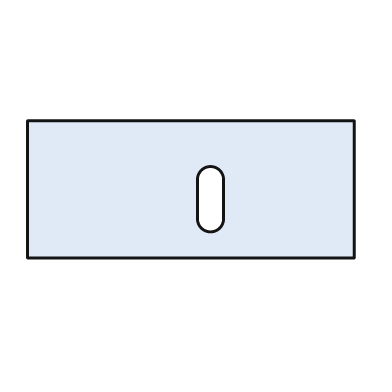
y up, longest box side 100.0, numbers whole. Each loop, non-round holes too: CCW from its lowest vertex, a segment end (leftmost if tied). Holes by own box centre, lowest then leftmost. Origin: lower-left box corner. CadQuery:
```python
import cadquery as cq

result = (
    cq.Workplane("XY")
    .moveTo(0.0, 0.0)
    .lineTo(100.0, 0.0)
    .lineTo(100.0, 42.0)
    .lineTo(0.0, 42.0)
    .close()
    .moveTo(52.0, 12.0)
    .threePointArc((56.0, 8.0), (60.0, 12.0))
    .lineTo(60.0, 24.0)
    .threePointArc((56.0, 28.0), (52.0, 24.0))
    .close()
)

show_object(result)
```